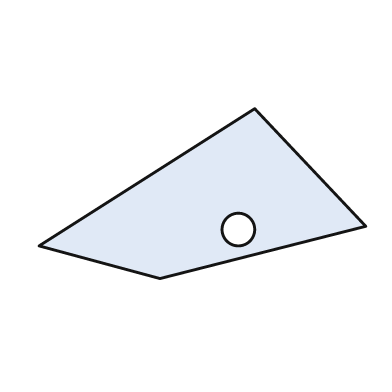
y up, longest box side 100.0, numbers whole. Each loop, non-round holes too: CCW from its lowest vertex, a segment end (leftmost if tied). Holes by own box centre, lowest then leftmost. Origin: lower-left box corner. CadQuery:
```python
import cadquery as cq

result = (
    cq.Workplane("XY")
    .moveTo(37.0, 0.0)
    .lineTo(100.0, 16.0)
    .lineTo(66.0, 52.0)
    .lineTo(0.0, 10.0)
    .close()
    .moveTo(61.0, 15.0)
    .circle(5.0)
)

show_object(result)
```